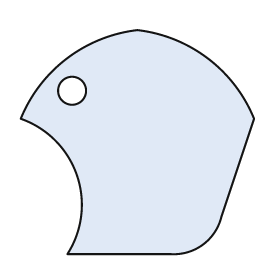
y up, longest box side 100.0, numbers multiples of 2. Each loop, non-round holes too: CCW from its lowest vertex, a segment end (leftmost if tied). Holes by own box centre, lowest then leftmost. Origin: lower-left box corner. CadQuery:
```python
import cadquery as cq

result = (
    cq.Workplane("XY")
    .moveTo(20.0, 0.0)
    .lineTo(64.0, 0.0)
    .threePointArc((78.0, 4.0), (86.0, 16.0))
    .lineTo(100.0, 58.0)
    .threePointArc((80.0, 84.0), (50.0, 96.0))
    .threePointArc((20.0, 84.0), (0.0, 58.0))
    .threePointArc((24.0, 34.0), (20.0, 0.0))
    .close()
    .moveTo(22.0, 70.0)
    .circle(6.0)
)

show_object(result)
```